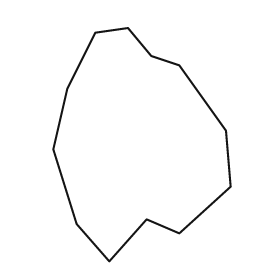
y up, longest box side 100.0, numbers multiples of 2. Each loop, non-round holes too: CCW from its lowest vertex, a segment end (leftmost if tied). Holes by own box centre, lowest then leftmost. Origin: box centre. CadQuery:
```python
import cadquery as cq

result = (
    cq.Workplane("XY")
    .moveTo(-14.0, -50.0)
    .lineTo(2.0, -32.0)
    .lineTo(16.0, -38.0)
    .lineTo(38.0, -18.0)
    .lineTo(36.0, 6.0)
    .lineTo(16.0, 34.0)
    .lineTo(4.0, 38.0)
    .lineTo(-6.0, 50.0)
    .lineTo(-20.0, 48.0)
    .lineTo(-32.0, 24.0)
    .lineTo(-38.0, -2.0)
    .lineTo(-28.0, -34.0)
    .close()
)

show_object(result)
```